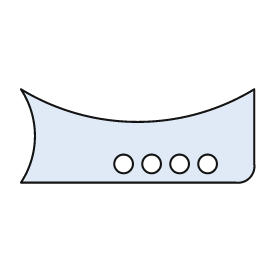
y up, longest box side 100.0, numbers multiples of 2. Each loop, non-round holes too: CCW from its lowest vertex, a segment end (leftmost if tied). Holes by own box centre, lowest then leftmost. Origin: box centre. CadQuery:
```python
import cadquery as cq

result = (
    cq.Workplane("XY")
    .moveTo(-50.0, -20.0)
    .lineTo(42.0, -20.0)
    .threePointArc((48.0, -18.0), (50.0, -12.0))
    .lineTo(50.0, 20.0)
    .threePointArc((0.0, 6.0), (-50.0, 20.0))
    .threePointArc((-44.0, 0.0), (-50.0, -20.0))
    .close()
    .moveTo(-6.0, -12.0)
    .circle(4.0)
    .moveTo(6.0, -12.0)
    .circle(4.0)
    .moveTo(18.0, -12.0)
    .circle(4.0)
    .moveTo(30.0, -12.0)
    .circle(4.0)
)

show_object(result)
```